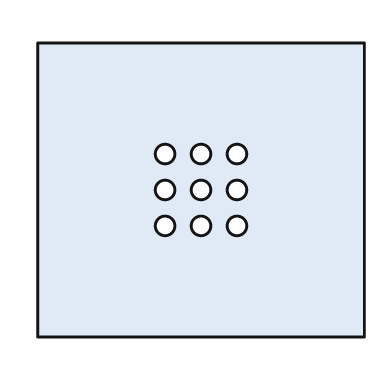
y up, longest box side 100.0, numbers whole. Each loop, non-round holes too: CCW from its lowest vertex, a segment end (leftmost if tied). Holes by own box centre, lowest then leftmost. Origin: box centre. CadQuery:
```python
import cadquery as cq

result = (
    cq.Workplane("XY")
    .moveTo(-50.0, -45.0)
    .lineTo(50.0, -45.0)
    .lineTo(50.0, 45.0)
    .lineTo(-50.0, 45.0)
    .close()
    .moveTo(-11.0, -11.0)
    .circle(3.0)
    .moveTo(0.0, -11.0)
    .circle(3.0)
    .moveTo(11.0, -11.0)
    .circle(3.0)
    .moveTo(-11.0, 0.0)
    .circle(3.0)
    .moveTo(0.0, 0.0)
    .circle(3.0)
    .moveTo(11.0, 0.0)
    .circle(3.0)
    .moveTo(-11.0, 11.0)
    .circle(3.0)
    .moveTo(0.0, 11.0)
    .circle(3.0)
    .moveTo(11.0, 11.0)
    .circle(3.0)
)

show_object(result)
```